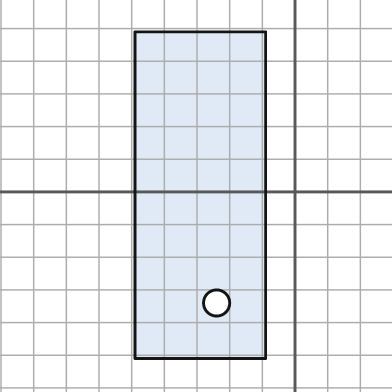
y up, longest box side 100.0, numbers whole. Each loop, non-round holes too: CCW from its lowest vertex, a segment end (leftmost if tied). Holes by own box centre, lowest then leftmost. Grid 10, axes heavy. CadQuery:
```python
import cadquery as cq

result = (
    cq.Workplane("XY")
    .moveTo(-49.0, -51.0)
    .lineTo(-9.0, -51.0)
    .lineTo(-9.0, 49.0)
    .lineTo(-49.0, 49.0)
    .close()
    .moveTo(-24.0, -34.0)
    .circle(4.0)
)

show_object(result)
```